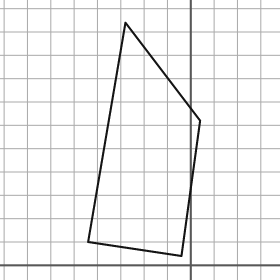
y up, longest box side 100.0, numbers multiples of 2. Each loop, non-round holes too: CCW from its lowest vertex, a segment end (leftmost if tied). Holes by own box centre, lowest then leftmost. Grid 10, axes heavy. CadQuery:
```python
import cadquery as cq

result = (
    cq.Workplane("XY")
    .moveTo(-4.0, 4.0)
    .lineTo(4.0, 62.0)
    .lineTo(-28.0, 104.0)
    .lineTo(-44.0, 10.0)
    .close()
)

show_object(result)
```